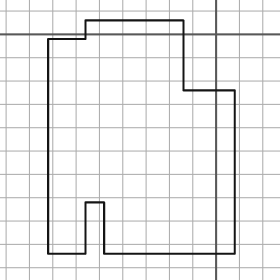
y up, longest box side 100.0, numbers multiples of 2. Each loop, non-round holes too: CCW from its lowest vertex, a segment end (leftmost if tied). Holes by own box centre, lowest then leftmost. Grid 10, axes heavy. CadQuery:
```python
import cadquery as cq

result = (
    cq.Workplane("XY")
    .moveTo(-72.0, -94.0)
    .lineTo(-56.0, -94.0)
    .lineTo(-56.0, -72.0)
    .lineTo(-48.0, -72.0)
    .lineTo(-48.0, -94.0)
    .lineTo(8.0, -94.0)
    .lineTo(8.0, -24.0)
    .lineTo(-14.0, -24.0)
    .lineTo(-14.0, 6.0)
    .lineTo(-56.0, 6.0)
    .lineTo(-56.0, -2.0)
    .lineTo(-72.0, -2.0)
    .close()
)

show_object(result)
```